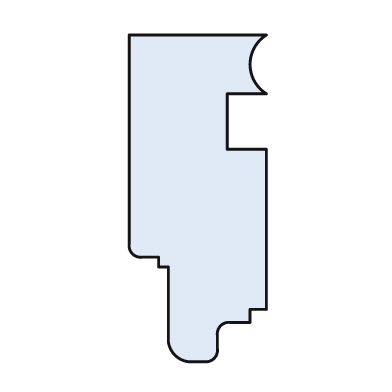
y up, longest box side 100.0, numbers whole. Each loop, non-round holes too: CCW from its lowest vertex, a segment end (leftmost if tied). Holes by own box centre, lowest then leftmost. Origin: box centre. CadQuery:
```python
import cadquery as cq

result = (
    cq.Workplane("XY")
    .moveTo(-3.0, -50.0)
    .lineTo(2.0, -50.0)
    .threePointArc((5.0, -49.0), (6.0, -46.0))
    .lineTo(6.0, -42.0)
    .threePointArc((7.0, -39.0), (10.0, -38.0))
    .lineTo(16.0, -38.0)
    .lineTo(16.0, -34.0)
    .lineTo(21.0, -34.0)
    .lineTo(21.0, 15.0)
    .lineTo(9.0, 15.0)
    .lineTo(9.0, 32.0)
    .lineTo(21.0, 32.0)
    .threePointArc((16.0, 41.0), (21.0, 50.0))
    .lineTo(-21.0, 50.0)
    .lineTo(-21.0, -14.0)
    .threePointArc((-20.0, -17.0), (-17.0, -18.0))
    .lineTo(-12.0, -18.0)
    .lineTo(-12.0, -21.0)
    .lineTo(-9.0, -21.0)
    .lineTo(-9.0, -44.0)
    .threePointArc((-7.0, -48.0), (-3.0, -50.0))
    .close()
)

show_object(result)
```